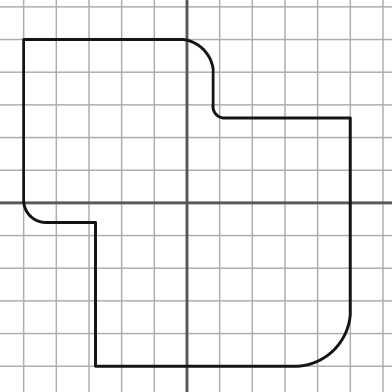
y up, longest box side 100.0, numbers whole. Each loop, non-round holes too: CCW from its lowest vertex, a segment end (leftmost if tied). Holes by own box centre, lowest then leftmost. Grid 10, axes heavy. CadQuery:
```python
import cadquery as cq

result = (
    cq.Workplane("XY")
    .moveTo(-28.0, -50.0)
    .lineTo(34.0, -50.0)
    .threePointArc((45.0, -45.0), (50.0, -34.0))
    .lineTo(50.0, 26.0)
    .lineTo(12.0, 26.0)
    .threePointArc((9.0, 27.0), (8.0, 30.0))
    .lineTo(8.0, 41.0)
    .threePointArc((5.0, 47.0), (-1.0, 50.0))
    .lineTo(-50.0, 50.0)
    .lineTo(-50.0, 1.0)
    .threePointArc((-48.0, -4.0), (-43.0, -6.0))
    .lineTo(-28.0, -6.0)
    .close()
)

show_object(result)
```